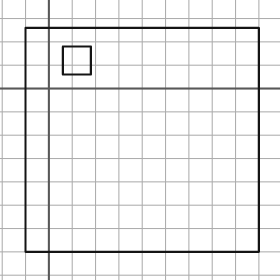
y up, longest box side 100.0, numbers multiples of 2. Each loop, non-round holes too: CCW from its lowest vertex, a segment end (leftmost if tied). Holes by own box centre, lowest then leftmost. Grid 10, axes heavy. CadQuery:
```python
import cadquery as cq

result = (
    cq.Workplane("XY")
    .moveTo(-10.0, -70.0)
    .lineTo(90.0, -70.0)
    .lineTo(90.0, 26.0)
    .lineTo(-10.0, 26.0)
    .close()
    .moveTo(6.0, 6.0)
    .lineTo(18.0, 6.0)
    .lineTo(18.0, 18.0)
    .lineTo(6.0, 18.0)
    .close()
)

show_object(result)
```